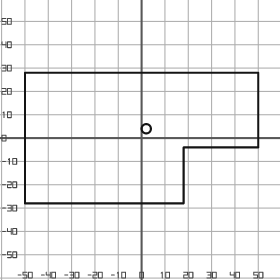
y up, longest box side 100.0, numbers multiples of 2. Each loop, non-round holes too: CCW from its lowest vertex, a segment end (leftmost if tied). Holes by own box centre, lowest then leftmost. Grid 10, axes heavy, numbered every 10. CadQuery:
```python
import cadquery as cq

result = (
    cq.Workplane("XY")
    .moveTo(-50.0, -28.0)
    .lineTo(18.0, -28.0)
    .lineTo(18.0, -4.0)
    .lineTo(50.0, -4.0)
    .lineTo(50.0, 28.0)
    .lineTo(-50.0, 28.0)
    .close()
    .moveTo(2.0, 4.0)
    .circle(2.0)
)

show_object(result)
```